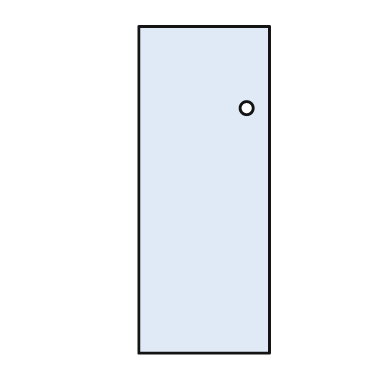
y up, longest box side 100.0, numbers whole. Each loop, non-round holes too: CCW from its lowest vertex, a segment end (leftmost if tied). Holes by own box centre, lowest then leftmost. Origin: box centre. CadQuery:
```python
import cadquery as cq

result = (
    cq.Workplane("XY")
    .moveTo(-20.0, -50.0)
    .lineTo(20.0, -50.0)
    .lineTo(20.0, 50.0)
    .lineTo(-20.0, 50.0)
    .close()
    .moveTo(13.0, 25.0)
    .circle(2.0)
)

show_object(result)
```